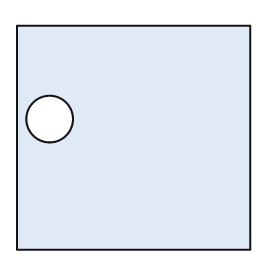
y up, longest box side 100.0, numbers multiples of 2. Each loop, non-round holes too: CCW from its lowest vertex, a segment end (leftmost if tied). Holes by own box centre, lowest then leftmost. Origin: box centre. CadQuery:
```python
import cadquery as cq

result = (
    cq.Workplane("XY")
    .moveTo(-50.0, -48.0)
    .lineTo(50.0, -48.0)
    .lineTo(50.0, 48.0)
    .lineTo(-50.0, 48.0)
    .close()
    .moveTo(-36.0, 8.0)
    .circle(10.0)
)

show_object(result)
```